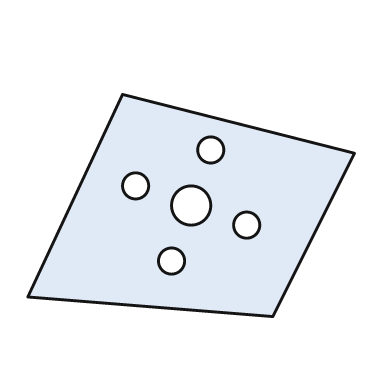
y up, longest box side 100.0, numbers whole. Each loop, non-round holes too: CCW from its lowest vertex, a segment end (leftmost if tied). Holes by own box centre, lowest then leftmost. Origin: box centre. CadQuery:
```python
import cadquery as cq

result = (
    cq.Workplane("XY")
    .moveTo(25.0, -34.0)
    .lineTo(50.0, 16.0)
    .lineTo(-21.0, 34.0)
    .lineTo(-50.0, -28.0)
    .close()
    .moveTo(-6.0, -17.0)
    .circle(4.0)
    .moveTo(17.0, -6.0)
    .circle(4.0)
    .moveTo(0.0, 0.0)
    .circle(6.0)
    .moveTo(-17.0, 6.0)
    .circle(4.0)
    .moveTo(6.0, 17.0)
    .circle(4.0)
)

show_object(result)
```